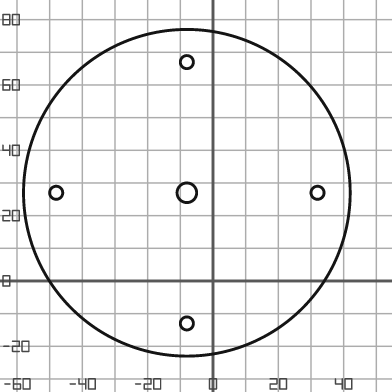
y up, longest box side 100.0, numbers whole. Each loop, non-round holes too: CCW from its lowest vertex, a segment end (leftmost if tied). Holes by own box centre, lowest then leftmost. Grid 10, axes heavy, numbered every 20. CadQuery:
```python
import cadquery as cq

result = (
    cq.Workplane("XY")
    .moveTo(-8.0, 27.0)
    .circle(50.0)
    .moveTo(-8.0, -13.0)
    .circle(2.0)
    .moveTo(-48.0, 27.0)
    .circle(2.0)
    .moveTo(-8.0, 27.0)
    .circle(3.0)
    .moveTo(32.0, 27.0)
    .circle(2.0)
    .moveTo(-8.0, 67.0)
    .circle(2.0)
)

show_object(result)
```